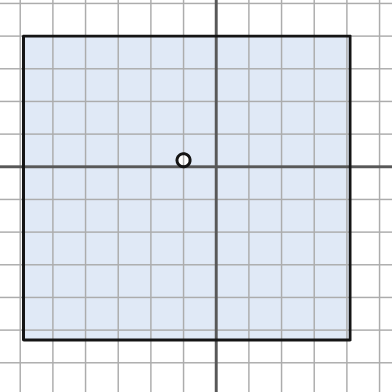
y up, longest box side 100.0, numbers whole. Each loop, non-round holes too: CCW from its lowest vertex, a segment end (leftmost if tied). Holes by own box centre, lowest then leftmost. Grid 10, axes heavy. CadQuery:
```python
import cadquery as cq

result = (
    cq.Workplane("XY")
    .moveTo(-59.0, -53.0)
    .lineTo(41.0, -53.0)
    .lineTo(41.0, 40.0)
    .lineTo(-59.0, 40.0)
    .close()
    .moveTo(-10.0, 2.0)
    .circle(2.0)
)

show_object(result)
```